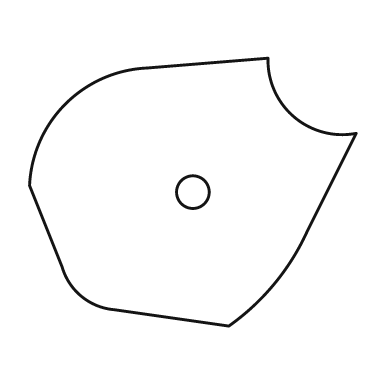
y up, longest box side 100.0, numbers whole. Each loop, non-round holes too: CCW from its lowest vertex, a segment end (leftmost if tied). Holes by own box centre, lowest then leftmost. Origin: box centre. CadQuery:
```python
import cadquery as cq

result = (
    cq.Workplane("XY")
    .moveTo(11.0, -41.0)
    .threePointArc((25.0, -28.0), (35.0, -12.0))
    .lineTo(50.0, 18.0)
    .threePointArc((31.0, 23.0), (23.0, 41.0))
    .lineTo(-14.0, 38.0)
    .threePointArc((-39.0, 27.0), (-50.0, 2.0))
    .lineTo(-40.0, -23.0)
    .threePointArc((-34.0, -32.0), (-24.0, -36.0))
    .close()
    .moveTo(0.0, 0.0)
    .circle(5.0)
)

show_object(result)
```